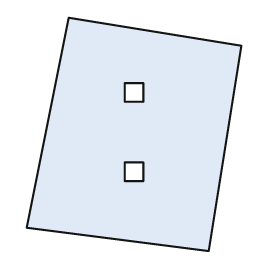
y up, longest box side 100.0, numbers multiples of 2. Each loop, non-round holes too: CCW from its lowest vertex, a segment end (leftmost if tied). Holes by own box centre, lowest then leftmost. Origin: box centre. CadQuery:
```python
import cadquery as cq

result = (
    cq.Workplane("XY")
    .moveTo(32.0, -50.0)
    .lineTo(46.0, 38.0)
    .lineTo(-28.0, 50.0)
    .lineTo(-46.0, -40.0)
    .close()
    .moveTo(-4.0, -20.0)
    .lineTo(4.0, -20.0)
    .lineTo(4.0, -12.0)
    .lineTo(-4.0, -12.0)
    .close()
    .moveTo(-4.0, 14.0)
    .lineTo(4.0, 14.0)
    .lineTo(4.0, 22.0)
    .lineTo(-4.0, 22.0)
    .close()
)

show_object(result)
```